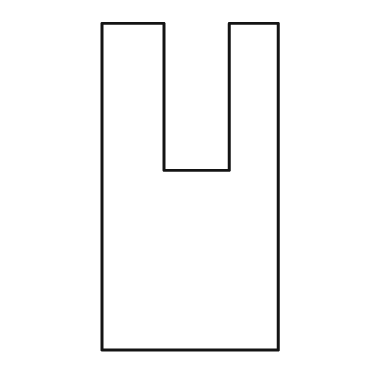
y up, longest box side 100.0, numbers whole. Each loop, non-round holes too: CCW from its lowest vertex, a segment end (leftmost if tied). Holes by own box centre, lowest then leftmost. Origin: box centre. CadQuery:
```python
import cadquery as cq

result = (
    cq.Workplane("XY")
    .moveTo(-27.0, -50.0)
    .lineTo(27.0, -50.0)
    .lineTo(27.0, 50.0)
    .lineTo(12.0, 50.0)
    .lineTo(12.0, 5.0)
    .lineTo(-8.0, 5.0)
    .lineTo(-8.0, 50.0)
    .lineTo(-27.0, 50.0)
    .close()
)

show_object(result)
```